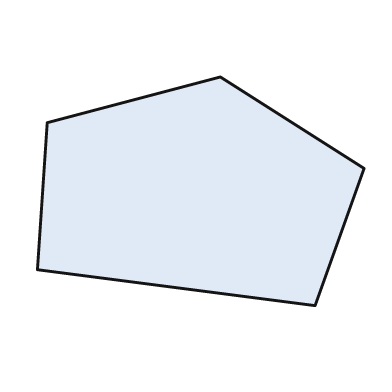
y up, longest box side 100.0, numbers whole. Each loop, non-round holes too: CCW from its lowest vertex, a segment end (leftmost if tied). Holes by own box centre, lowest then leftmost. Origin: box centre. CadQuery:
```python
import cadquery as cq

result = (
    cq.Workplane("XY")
    .moveTo(35.0, -35.0)
    .lineTo(50.0, 7.0)
    .lineTo(6.0, 35.0)
    .lineTo(-47.0, 21.0)
    .lineTo(-50.0, -24.0)
    .close()
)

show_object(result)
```